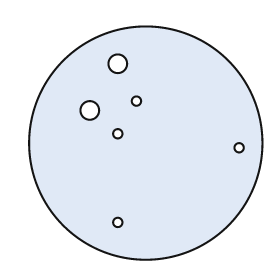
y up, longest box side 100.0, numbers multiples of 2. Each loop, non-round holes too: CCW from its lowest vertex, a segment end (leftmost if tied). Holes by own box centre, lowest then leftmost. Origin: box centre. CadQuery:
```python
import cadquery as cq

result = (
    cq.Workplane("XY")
    .moveTo(0.0, 0.0)
    .circle(50.0)
    .moveTo(-12.0, -34.0)
    .circle(2.0)
    .moveTo(40.0, -2.0)
    .circle(2.0)
    .moveTo(-12.0, 4.0)
    .circle(2.0)
    .moveTo(-24.0, 14.0)
    .circle(4.0)
    .moveTo(-4.0, 18.0)
    .circle(2.0)
    .moveTo(-12.0, 34.0)
    .circle(4.0)
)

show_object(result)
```